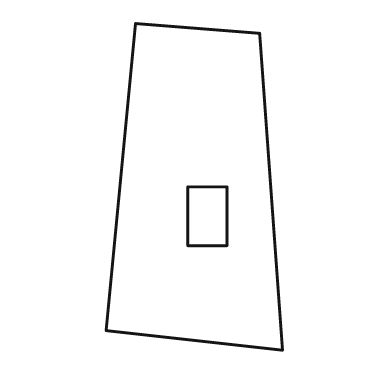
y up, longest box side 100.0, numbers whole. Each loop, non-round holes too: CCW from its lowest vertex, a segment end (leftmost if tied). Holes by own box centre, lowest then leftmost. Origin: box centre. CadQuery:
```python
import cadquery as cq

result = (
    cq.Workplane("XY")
    .moveTo(27.0, -50.0)
    .lineTo(20.0, 47.0)
    .lineTo(-18.0, 50.0)
    .lineTo(-27.0, -44.0)
    .close()
    .moveTo(-2.0, -18.0)
    .lineTo(10.0, -18.0)
    .lineTo(10.0, 0.0)
    .lineTo(-2.0, 0.0)
    .close()
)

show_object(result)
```